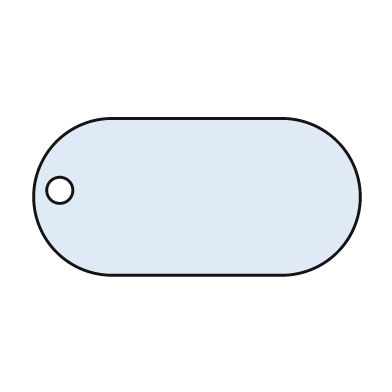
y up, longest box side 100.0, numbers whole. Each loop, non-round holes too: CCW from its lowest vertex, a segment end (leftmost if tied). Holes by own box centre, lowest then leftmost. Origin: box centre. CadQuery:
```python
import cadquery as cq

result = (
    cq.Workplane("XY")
    .moveTo(-26.0, -24.0)
    .lineTo(26.0, -24.0)
    .threePointArc((50.0, 0.0), (26.0, 24.0))
    .lineTo(-26.0, 24.0)
    .threePointArc((-50.0, 0.0), (-26.0, -24.0))
    .close()
    .moveTo(-42.0, 2.0)
    .circle(4.0)
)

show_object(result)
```